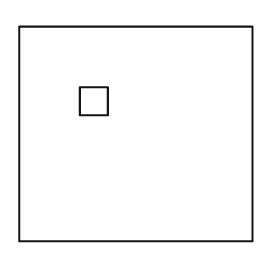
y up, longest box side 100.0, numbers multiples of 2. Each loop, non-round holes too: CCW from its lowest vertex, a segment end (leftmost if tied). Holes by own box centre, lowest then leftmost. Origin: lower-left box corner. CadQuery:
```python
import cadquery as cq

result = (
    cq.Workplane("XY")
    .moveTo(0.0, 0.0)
    .lineTo(100.0, 0.0)
    .lineTo(100.0, 92.0)
    .lineTo(0.0, 92.0)
    .close()
    .moveTo(26.0, 54.0)
    .lineTo(38.0, 54.0)
    .lineTo(38.0, 66.0)
    .lineTo(26.0, 66.0)
    .close()
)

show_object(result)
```